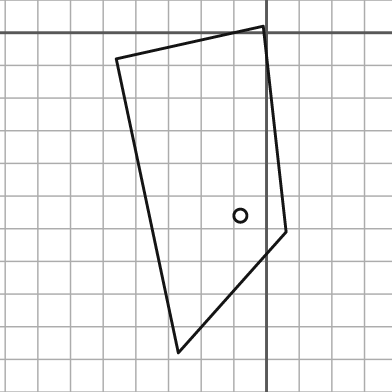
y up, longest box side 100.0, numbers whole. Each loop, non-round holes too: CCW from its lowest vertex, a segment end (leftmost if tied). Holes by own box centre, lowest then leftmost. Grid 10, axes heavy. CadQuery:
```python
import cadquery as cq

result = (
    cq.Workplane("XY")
    .moveTo(-27.0, -98.0)
    .lineTo(6.0, -61.0)
    .lineTo(-1.0, 2.0)
    .lineTo(-46.0, -8.0)
    .close()
    .moveTo(-8.0, -56.0)
    .circle(2.0)
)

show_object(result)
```